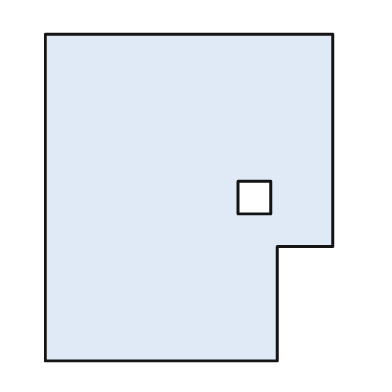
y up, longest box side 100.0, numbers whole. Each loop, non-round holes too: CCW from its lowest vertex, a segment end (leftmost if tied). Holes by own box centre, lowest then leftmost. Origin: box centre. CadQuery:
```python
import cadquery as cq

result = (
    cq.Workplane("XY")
    .moveTo(-44.0, -50.0)
    .lineTo(27.0, -50.0)
    .lineTo(27.0, -15.0)
    .lineTo(44.0, -15.0)
    .lineTo(44.0, 50.0)
    .lineTo(-44.0, 50.0)
    .close()
    .moveTo(15.0, -5.0)
    .lineTo(25.0, -5.0)
    .lineTo(25.0, 5.0)
    .lineTo(15.0, 5.0)
    .close()
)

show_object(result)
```